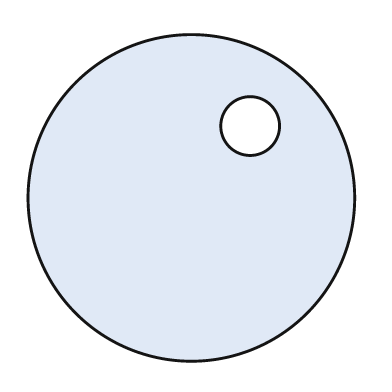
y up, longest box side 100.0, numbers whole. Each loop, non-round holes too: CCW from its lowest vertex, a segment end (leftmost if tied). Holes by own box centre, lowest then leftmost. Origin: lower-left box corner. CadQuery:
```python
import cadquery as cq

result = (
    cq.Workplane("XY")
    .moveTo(50.0, 50.0)
    .circle(50.0)
    .moveTo(68.0, 72.0)
    .circle(9.0)
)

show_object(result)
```